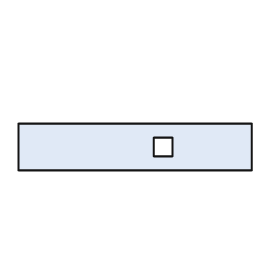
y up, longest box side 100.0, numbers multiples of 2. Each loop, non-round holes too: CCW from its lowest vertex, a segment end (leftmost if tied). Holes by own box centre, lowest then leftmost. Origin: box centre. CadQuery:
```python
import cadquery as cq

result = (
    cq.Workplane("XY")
    .moveTo(-50.0, -10.0)
    .lineTo(50.0, -10.0)
    .lineTo(50.0, 10.0)
    .lineTo(-50.0, 10.0)
    .close()
    .moveTo(8.0, -4.0)
    .lineTo(16.0, -4.0)
    .lineTo(16.0, 4.0)
    .lineTo(8.0, 4.0)
    .close()
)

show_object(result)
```